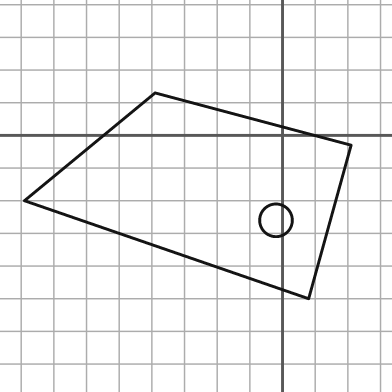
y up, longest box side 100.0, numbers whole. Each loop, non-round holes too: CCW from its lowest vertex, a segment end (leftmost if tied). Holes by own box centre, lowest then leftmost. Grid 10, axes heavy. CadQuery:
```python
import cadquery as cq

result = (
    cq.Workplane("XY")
    .moveTo(8.0, -50.0)
    .lineTo(21.0, -3.0)
    .lineTo(-39.0, 13.0)
    .lineTo(-79.0, -20.0)
    .close()
    .moveTo(-2.0, -26.0)
    .circle(5.0)
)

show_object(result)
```